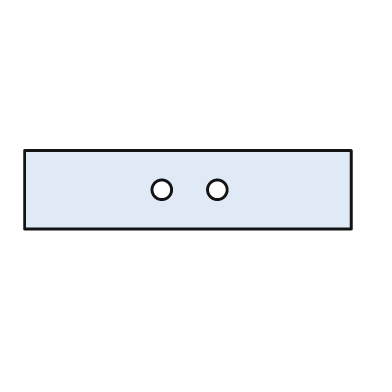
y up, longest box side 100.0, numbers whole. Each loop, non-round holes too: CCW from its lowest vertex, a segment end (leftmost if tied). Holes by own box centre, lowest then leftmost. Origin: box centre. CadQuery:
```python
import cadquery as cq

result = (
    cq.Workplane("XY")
    .moveTo(-50.0, -12.0)
    .lineTo(50.0, -12.0)
    .lineTo(50.0, 12.0)
    .lineTo(-50.0, 12.0)
    .close()
    .moveTo(-8.0, 0.0)
    .circle(3.0)
    .moveTo(9.0, 0.0)
    .circle(3.0)
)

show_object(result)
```